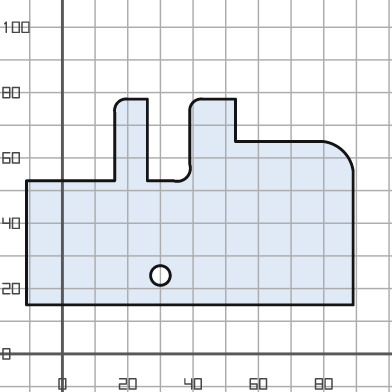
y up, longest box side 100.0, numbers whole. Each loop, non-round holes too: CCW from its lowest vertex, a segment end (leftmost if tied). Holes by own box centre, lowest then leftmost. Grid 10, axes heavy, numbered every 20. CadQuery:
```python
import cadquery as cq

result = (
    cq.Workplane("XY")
    .moveTo(-11.0, 15.0)
    .lineTo(89.0, 15.0)
    .lineTo(89.0, 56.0)
    .threePointArc((86.0, 62.0), (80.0, 65.0))
    .lineTo(53.0, 65.0)
    .lineTo(53.0, 78.0)
    .lineTo(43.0, 78.0)
    .threePointArc((40.0, 77.0), (39.0, 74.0))
    .lineTo(39.0, 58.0)
    .threePointArc((38.0, 54.0), (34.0, 53.0))
    .lineTo(26.0, 53.0)
    .lineTo(26.0, 78.0)
    .lineTo(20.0, 78.0)
    .threePointArc((17.0, 77.0), (16.0, 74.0))
    .lineTo(16.0, 53.0)
    .lineTo(-11.0, 53.0)
    .close()
    .moveTo(30.0, 24.0)
    .circle(3.0)
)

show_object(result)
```